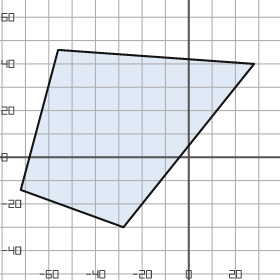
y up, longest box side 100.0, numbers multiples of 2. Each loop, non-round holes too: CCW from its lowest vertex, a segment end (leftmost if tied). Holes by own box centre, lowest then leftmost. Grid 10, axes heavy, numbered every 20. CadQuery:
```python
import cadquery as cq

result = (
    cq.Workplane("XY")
    .moveTo(-28.0, -30.0)
    .lineTo(28.0, 40.0)
    .lineTo(-56.0, 46.0)
    .lineTo(-72.0, -14.0)
    .close()
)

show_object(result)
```